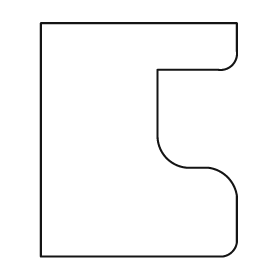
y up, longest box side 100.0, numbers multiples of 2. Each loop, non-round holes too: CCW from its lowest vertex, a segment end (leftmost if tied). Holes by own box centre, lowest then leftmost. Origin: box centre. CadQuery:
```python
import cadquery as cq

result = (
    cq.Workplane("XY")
    .moveTo(-42.0, -50.0)
    .lineTo(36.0, -50.0)
    .threePointArc((40.0, -48.0), (42.0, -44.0))
    .lineTo(42.0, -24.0)
    .threePointArc((38.0, -16.0), (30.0, -12.0))
    .lineTo(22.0, -12.0)
    .threePointArc((12.0, -8.0), (8.0, 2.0))
    .lineTo(8.0, 30.0)
    .lineTo(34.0, 30.0)
    .threePointArc((40.0, 32.0), (42.0, 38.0))
    .lineTo(42.0, 50.0)
    .lineTo(-42.0, 50.0)
    .close()
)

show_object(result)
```